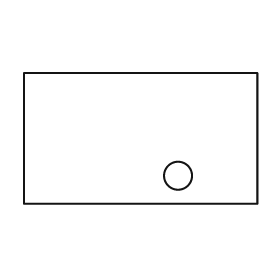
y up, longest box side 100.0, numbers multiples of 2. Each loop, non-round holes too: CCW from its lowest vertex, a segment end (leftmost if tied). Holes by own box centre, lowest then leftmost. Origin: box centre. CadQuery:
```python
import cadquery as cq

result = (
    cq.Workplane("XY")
    .moveTo(-50.0, -28.0)
    .lineTo(50.0, -28.0)
    .lineTo(50.0, 28.0)
    .lineTo(-50.0, 28.0)
    .close()
    .moveTo(16.0, -16.0)
    .circle(6.0)
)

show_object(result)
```